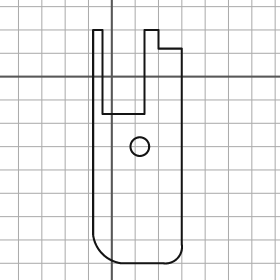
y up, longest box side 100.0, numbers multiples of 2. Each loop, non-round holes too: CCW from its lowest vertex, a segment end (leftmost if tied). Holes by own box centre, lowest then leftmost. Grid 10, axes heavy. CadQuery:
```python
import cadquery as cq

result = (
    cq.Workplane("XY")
    .moveTo(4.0, -80.0)
    .lineTo(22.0, -80.0)
    .threePointArc((28.0, -78.0), (30.0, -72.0))
    .lineTo(30.0, 12.0)
    .lineTo(20.0, 12.0)
    .lineTo(20.0, 20.0)
    .lineTo(14.0, 20.0)
    .lineTo(14.0, -16.0)
    .lineTo(-4.0, -16.0)
    .lineTo(-4.0, 20.0)
    .lineTo(-8.0, 20.0)
    .lineTo(-8.0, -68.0)
    .threePointArc((-4.0, -76.0), (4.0, -80.0))
    .close()
    .moveTo(12.0, -30.0)
    .circle(4.0)
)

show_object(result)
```